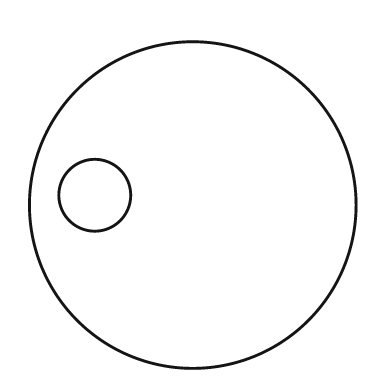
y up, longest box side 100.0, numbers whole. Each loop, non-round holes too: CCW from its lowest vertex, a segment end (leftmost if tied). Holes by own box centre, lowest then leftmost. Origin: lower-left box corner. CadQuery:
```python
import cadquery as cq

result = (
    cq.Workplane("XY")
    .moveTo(50.0, 50.0)
    .circle(50.0)
    .moveTo(20.0, 53.0)
    .circle(11.0)
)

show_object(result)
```